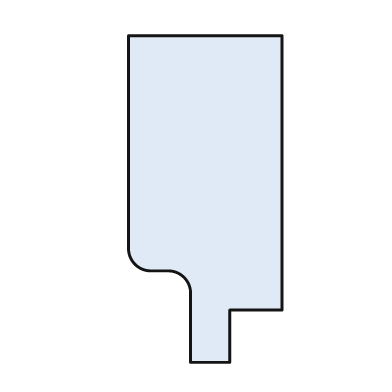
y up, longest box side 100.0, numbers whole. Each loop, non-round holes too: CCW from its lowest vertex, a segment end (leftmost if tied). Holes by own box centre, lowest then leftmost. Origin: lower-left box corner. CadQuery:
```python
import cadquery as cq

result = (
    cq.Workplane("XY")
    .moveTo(19.0, 0.0)
    .lineTo(31.0, 0.0)
    .lineTo(31.0, 16.0)
    .lineTo(47.0, 16.0)
    .lineTo(47.0, 100.0)
    .lineTo(0.0, 100.0)
    .lineTo(0.0, 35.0)
    .threePointArc((2.0, 30.0), (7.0, 28.0))
    .lineTo(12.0, 28.0)
    .threePointArc((17.0, 26.0), (19.0, 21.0))
    .close()
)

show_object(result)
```